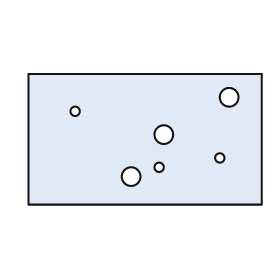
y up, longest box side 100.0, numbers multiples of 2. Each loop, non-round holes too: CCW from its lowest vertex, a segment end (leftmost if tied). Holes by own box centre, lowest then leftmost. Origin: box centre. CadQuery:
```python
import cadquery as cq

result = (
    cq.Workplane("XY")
    .moveTo(-50.0, -28.0)
    .lineTo(50.0, -28.0)
    .lineTo(50.0, 28.0)
    .lineTo(-50.0, 28.0)
    .close()
    .moveTo(-6.0, -16.0)
    .circle(4.0)
    .moveTo(6.0, -12.0)
    .circle(2.0)
    .moveTo(32.0, -8.0)
    .circle(2.0)
    .moveTo(8.0, 2.0)
    .circle(4.0)
    .moveTo(-30.0, 12.0)
    .circle(2.0)
    .moveTo(36.0, 18.0)
    .circle(4.0)
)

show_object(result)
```